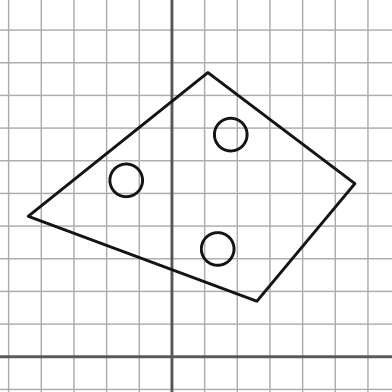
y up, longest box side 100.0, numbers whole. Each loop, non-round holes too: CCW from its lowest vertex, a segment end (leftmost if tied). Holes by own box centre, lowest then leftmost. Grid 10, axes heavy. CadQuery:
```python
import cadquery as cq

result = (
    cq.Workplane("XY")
    .moveTo(26.0, 17.0)
    .lineTo(56.0, 53.0)
    .lineTo(11.0, 87.0)
    .lineTo(-44.0, 43.0)
    .close()
    .moveTo(14.0, 33.0)
    .circle(5.0)
    .moveTo(-14.0, 54.0)
    .circle(5.0)
    .moveTo(18.0, 68.0)
    .circle(5.0)
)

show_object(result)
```